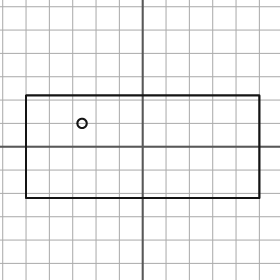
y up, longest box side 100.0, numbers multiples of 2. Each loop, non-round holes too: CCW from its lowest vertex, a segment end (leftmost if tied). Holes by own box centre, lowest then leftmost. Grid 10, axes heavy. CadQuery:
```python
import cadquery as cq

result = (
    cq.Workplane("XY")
    .moveTo(-50.0, -22.0)
    .lineTo(50.0, -22.0)
    .lineTo(50.0, 22.0)
    .lineTo(-50.0, 22.0)
    .close()
    .moveTo(-26.0, 10.0)
    .circle(2.0)
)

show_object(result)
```